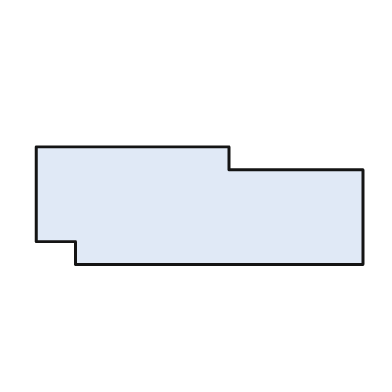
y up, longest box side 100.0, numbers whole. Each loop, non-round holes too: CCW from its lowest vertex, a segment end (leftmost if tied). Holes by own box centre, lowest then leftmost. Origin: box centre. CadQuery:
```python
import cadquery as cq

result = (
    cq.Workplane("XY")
    .moveTo(-38.0, -18.0)
    .lineTo(50.0, -18.0)
    .lineTo(50.0, 11.0)
    .lineTo(9.0, 11.0)
    .lineTo(9.0, 18.0)
    .lineTo(-50.0, 18.0)
    .lineTo(-50.0, -11.0)
    .lineTo(-38.0, -11.0)
    .close()
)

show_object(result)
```